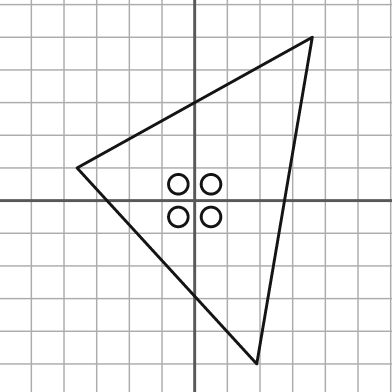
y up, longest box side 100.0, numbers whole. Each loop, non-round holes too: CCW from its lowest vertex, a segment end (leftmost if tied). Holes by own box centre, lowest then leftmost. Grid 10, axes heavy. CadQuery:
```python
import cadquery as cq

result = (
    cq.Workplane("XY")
    .moveTo(19.0, -50.0)
    .lineTo(36.0, 50.0)
    .lineTo(-36.0, 10.0)
    .close()
    .moveTo(-5.0, -5.0)
    .circle(3.0)
    .moveTo(5.0, -5.0)
    .circle(3.0)
    .moveTo(-5.0, 5.0)
    .circle(3.0)
    .moveTo(5.0, 5.0)
    .circle(3.0)
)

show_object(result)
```